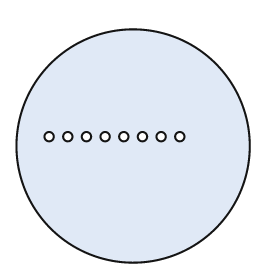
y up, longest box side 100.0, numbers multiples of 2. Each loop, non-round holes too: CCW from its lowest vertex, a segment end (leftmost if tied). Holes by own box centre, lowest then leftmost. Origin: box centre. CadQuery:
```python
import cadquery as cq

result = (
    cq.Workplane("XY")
    .moveTo(0.0, 0.0)
    .circle(50.0)
    .moveTo(-36.0, 4.0)
    .circle(2.0)
    .moveTo(-28.0, 4.0)
    .circle(2.0)
    .moveTo(-20.0, 4.0)
    .circle(2.0)
    .moveTo(-12.0, 4.0)
    .circle(2.0)
    .moveTo(-4.0, 4.0)
    .circle(2.0)
    .moveTo(4.0, 4.0)
    .circle(2.0)
    .moveTo(12.0, 4.0)
    .circle(2.0)
    .moveTo(20.0, 4.0)
    .circle(2.0)
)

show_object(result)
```